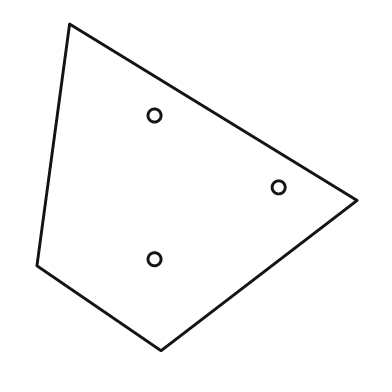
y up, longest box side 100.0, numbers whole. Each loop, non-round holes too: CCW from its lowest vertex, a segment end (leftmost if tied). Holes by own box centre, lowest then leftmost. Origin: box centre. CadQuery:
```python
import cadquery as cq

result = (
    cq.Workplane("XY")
    .moveTo(-11.0, -50.0)
    .lineTo(49.0, -4.0)
    .lineTo(-39.0, 50.0)
    .lineTo(-49.0, -24.0)
    .close()
    .moveTo(-13.0, -22.0)
    .circle(2.0)
    .moveTo(25.0, 0.0)
    .circle(2.0)
    .moveTo(-13.0, 22.0)
    .circle(2.0)
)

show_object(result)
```